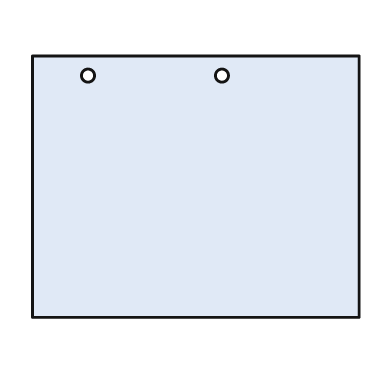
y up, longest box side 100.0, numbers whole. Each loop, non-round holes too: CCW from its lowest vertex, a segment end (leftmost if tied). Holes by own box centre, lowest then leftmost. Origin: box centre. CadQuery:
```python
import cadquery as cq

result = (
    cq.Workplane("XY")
    .moveTo(-50.0, -40.0)
    .lineTo(50.0, -40.0)
    .lineTo(50.0, 40.0)
    .lineTo(-50.0, 40.0)
    .close()
    .moveTo(-33.0, 34.0)
    .circle(2.0)
    .moveTo(8.0, 34.0)
    .circle(2.0)
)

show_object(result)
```